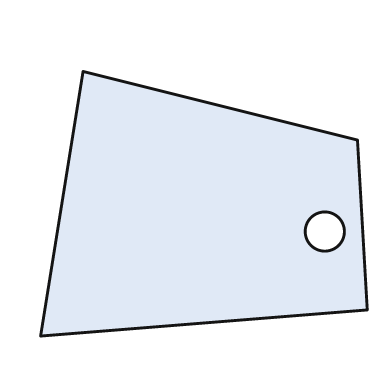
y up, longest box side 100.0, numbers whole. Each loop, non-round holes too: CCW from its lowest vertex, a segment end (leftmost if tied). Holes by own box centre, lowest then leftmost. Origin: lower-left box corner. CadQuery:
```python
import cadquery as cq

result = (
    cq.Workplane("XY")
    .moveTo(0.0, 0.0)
    .lineTo(100.0, 8.0)
    .lineTo(97.0, 60.0)
    .lineTo(13.0, 81.0)
    .close()
    .moveTo(87.0, 32.0)
    .circle(6.0)
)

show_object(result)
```